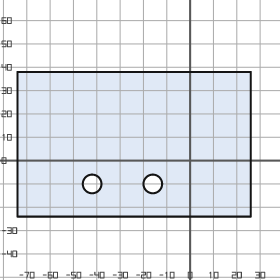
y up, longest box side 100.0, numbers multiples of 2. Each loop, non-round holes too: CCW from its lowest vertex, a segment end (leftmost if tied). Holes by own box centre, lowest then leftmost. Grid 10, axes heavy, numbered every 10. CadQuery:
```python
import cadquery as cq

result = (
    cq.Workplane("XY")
    .moveTo(-74.0, -24.0)
    .lineTo(26.0, -24.0)
    .lineTo(26.0, 38.0)
    .lineTo(-74.0, 38.0)
    .close()
    .moveTo(-42.0, -10.0)
    .circle(4.0)
    .moveTo(-16.0, -10.0)
    .circle(4.0)
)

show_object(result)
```